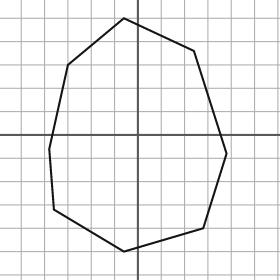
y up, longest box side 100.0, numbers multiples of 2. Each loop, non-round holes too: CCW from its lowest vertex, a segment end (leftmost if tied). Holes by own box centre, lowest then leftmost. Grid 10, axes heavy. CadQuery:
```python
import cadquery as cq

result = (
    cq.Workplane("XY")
    .moveTo(-6.0, -50.0)
    .lineTo(28.0, -40.0)
    .lineTo(38.0, -8.0)
    .lineTo(24.0, 36.0)
    .lineTo(-6.0, 50.0)
    .lineTo(-30.0, 30.0)
    .lineTo(-38.0, -6.0)
    .lineTo(-36.0, -32.0)
    .close()
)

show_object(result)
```